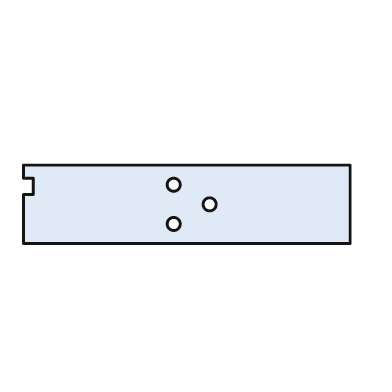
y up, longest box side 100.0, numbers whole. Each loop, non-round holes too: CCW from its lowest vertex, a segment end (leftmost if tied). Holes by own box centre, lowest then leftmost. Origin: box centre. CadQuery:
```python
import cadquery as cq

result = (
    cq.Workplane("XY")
    .moveTo(-50.0, -12.0)
    .lineTo(50.0, -12.0)
    .lineTo(50.0, 12.0)
    .lineTo(-50.0, 12.0)
    .lineTo(-50.0, 8.0)
    .lineTo(-47.0, 8.0)
    .lineTo(-47.0, 3.0)
    .lineTo(-50.0, 3.0)
    .close()
    .moveTo(-4.0, -6.0)
    .circle(2.0)
    .moveTo(7.0, 0.0)
    .circle(2.0)
    .moveTo(-4.0, 6.0)
    .circle(2.0)
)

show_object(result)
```